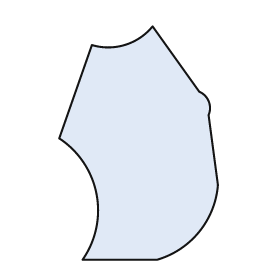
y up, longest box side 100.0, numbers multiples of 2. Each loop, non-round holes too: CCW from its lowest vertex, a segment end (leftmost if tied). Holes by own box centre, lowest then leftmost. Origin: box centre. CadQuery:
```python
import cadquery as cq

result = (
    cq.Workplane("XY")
    .moveTo(-24.0, -50.0)
    .lineTo(8.0, -50.0)
    .threePointArc((26.0, -38.0), (34.0, -18.0))
    .lineTo(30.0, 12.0)
    .threePointArc((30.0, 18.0), (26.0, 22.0))
    .lineTo(6.0, 50.0)
    .threePointArc((-6.0, 42.0), (-20.0, 42.0))
    .lineTo(-34.0, 2.0)
    .threePointArc((-18.0, -22.0), (-24.0, -50.0))
    .close()
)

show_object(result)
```